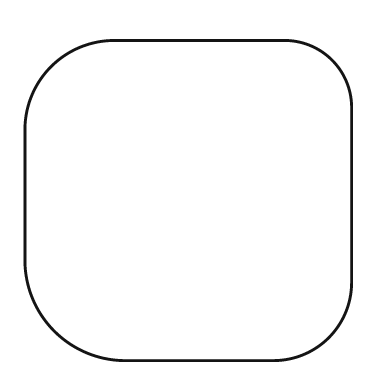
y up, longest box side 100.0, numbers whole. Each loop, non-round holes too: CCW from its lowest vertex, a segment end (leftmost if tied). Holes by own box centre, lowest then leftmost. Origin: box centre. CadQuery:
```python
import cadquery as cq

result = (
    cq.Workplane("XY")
    .moveTo(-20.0, -49.0)
    .lineTo(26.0, -49.0)
    .threePointArc((43.0, -42.0), (50.0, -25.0))
    .lineTo(50.0, 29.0)
    .threePointArc((44.0, 43.0), (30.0, 49.0))
    .lineTo(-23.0, 49.0)
    .threePointArc((-42.0, 41.0), (-50.0, 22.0))
    .lineTo(-50.0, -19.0)
    .threePointArc((-41.0, -40.0), (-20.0, -49.0))
    .close()
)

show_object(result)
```